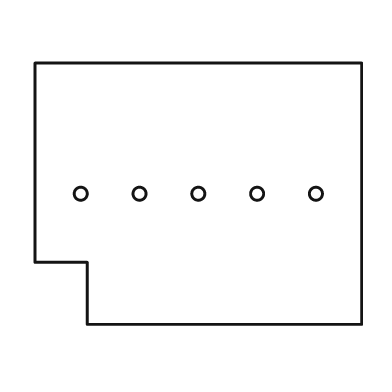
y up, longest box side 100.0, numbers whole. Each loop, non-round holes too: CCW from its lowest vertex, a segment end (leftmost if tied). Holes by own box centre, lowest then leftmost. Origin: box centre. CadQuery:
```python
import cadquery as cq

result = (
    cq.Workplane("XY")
    .moveTo(-34.0, -40.0)
    .lineTo(50.0, -40.0)
    .lineTo(50.0, 40.0)
    .lineTo(-50.0, 40.0)
    .lineTo(-50.0, -21.0)
    .lineTo(-34.0, -21.0)
    .close()
    .moveTo(-36.0, 0.0)
    .circle(2.0)
    .moveTo(-18.0, 0.0)
    .circle(2.0)
    .moveTo(0.0, 0.0)
    .circle(2.0)
    .moveTo(18.0, 0.0)
    .circle(2.0)
    .moveTo(36.0, 0.0)
    .circle(2.0)
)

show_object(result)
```